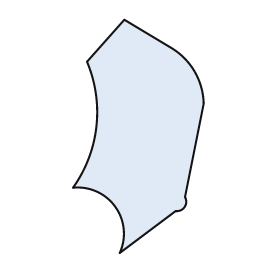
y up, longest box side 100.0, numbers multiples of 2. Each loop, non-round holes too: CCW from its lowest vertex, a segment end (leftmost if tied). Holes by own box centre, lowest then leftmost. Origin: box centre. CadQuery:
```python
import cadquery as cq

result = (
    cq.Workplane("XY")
    .moveTo(-8.0, -50.0)
    .lineTo(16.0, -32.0)
    .threePointArc((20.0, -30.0), (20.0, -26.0))
    .lineTo(28.0, 14.0)
    .threePointArc((24.0, 28.0), (14.0, 38.0))
    .lineTo(-6.0, 50.0)
    .lineTo(-22.0, 32.0)
    .threePointArc((-18.0, 4.0), (-28.0, -22.0))
    .threePointArc((-10.0, -30.0), (-8.0, -50.0))
    .close()
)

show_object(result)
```